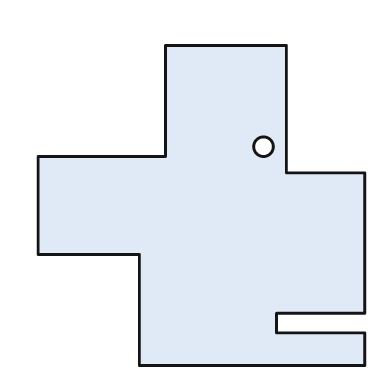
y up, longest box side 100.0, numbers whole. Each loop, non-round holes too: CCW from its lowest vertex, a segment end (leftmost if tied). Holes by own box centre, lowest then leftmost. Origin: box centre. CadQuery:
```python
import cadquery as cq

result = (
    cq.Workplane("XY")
    .moveTo(-19.0, -49.0)
    .lineTo(50.0, -49.0)
    .lineTo(50.0, -39.0)
    .lineTo(23.0, -39.0)
    .lineTo(23.0, -33.0)
    .lineTo(50.0, -33.0)
    .lineTo(50.0, 10.0)
    .lineTo(26.0, 10.0)
    .lineTo(26.0, 49.0)
    .lineTo(-11.0, 49.0)
    .lineTo(-11.0, 15.0)
    .lineTo(-50.0, 15.0)
    .lineTo(-50.0, -15.0)
    .lineTo(-19.0, -15.0)
    .close()
    .moveTo(19.0, 18.0)
    .circle(3.0)
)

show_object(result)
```